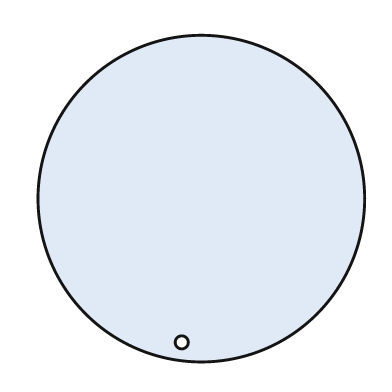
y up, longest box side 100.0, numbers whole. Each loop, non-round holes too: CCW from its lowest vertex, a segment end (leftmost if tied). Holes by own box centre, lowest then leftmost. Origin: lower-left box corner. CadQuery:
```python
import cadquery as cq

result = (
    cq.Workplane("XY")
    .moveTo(50.0, 50.0)
    .circle(50.0)
    .moveTo(44.0, 6.0)
    .circle(2.0)
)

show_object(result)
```